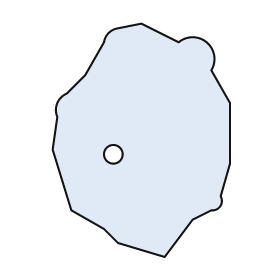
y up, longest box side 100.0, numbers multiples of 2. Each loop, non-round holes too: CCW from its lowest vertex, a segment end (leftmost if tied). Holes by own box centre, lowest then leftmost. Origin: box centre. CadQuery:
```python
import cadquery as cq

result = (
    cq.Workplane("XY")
    .moveTo(10.0, -50.0)
    .lineTo(22.0, -34.0)
    .lineTo(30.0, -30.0)
    .threePointArc((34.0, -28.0), (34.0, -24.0))
    .lineTo(38.0, -10.0)
    .lineTo(38.0, 16.0)
    .lineTo(30.0, 30.0)
    .threePointArc((28.0, 42.0), (16.0, 42.0))
    .lineTo(0.0, 50.0)
    .lineTo(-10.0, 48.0)
    .threePointArc((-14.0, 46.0), (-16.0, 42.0))
    .lineTo(-24.0, 28.0)
    .lineTo(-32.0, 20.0)
    .threePointArc((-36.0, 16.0), (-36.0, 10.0))
    .lineTo(-38.0, -4.0)
    .lineTo(-30.0, -30.0)
    .lineTo(-16.0, -38.0)
    .lineTo(-10.0, -44.0)
    .close()
    .moveTo(-12.0, -6.0)
    .circle(4.0)
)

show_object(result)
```